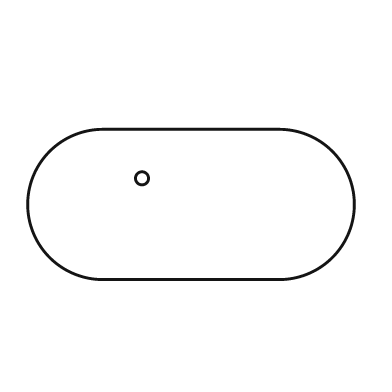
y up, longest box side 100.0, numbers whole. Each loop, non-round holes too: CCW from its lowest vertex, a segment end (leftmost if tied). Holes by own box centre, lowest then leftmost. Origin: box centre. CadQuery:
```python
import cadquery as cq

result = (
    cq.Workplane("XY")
    .moveTo(-27.0, -23.0)
    .lineTo(27.0, -23.0)
    .threePointArc((50.0, 0.0), (27.0, 23.0))
    .lineTo(-27.0, 23.0)
    .threePointArc((-50.0, 0.0), (-27.0, -23.0))
    .close()
    .moveTo(-15.0, 8.0)
    .circle(2.0)
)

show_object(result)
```